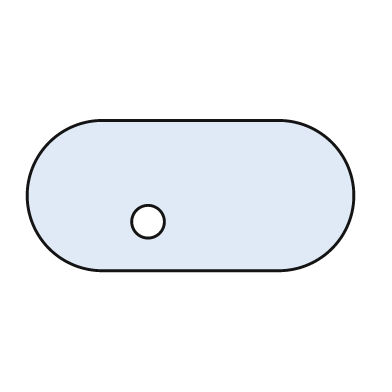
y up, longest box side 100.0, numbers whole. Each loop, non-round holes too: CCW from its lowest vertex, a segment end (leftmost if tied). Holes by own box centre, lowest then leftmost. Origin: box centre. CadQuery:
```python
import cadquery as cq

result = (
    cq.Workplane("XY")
    .moveTo(-27.0, -23.0)
    .lineTo(27.0, -23.0)
    .threePointArc((50.0, 0.0), (27.0, 23.0))
    .lineTo(-27.0, 23.0)
    .threePointArc((-50.0, 0.0), (-27.0, -23.0))
    .close()
    .moveTo(-13.0, -8.0)
    .circle(5.0)
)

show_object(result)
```